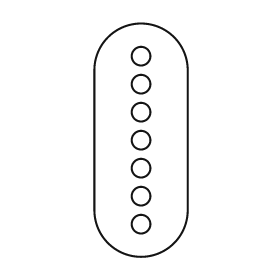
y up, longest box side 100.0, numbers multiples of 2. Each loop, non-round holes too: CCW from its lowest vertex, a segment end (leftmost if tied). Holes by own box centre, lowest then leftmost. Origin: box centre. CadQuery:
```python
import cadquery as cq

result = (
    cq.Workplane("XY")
    .moveTo(-20.0, -30.0)
    .threePointArc((0.0, -50.0), (20.0, -30.0))
    .lineTo(20.0, 30.0)
    .threePointArc((0.0, 50.0), (-20.0, 30.0))
    .close()
    .moveTo(0.0, -36.0)
    .circle(4.0)
    .moveTo(0.0, -24.0)
    .circle(4.0)
    .moveTo(0.0, -12.0)
    .circle(4.0)
    .moveTo(0.0, 0.0)
    .circle(4.0)
    .moveTo(0.0, 12.0)
    .circle(4.0)
    .moveTo(0.0, 24.0)
    .circle(4.0)
    .moveTo(0.0, 36.0)
    .circle(4.0)
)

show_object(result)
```